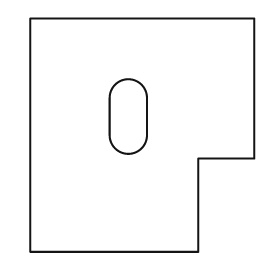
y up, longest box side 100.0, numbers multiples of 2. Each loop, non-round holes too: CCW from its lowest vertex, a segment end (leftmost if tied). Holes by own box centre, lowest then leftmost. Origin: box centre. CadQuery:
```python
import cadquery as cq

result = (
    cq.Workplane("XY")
    .moveTo(-48.0, -50.0)
    .lineTo(24.0, -50.0)
    .lineTo(24.0, -10.0)
    .lineTo(48.0, -10.0)
    .lineTo(48.0, 50.0)
    .lineTo(-48.0, 50.0)
    .close()
    .moveTo(-14.0, 0.0)
    .threePointArc((-6.0, -8.0), (2.0, 0.0))
    .lineTo(2.0, 16.0)
    .threePointArc((-6.0, 24.0), (-14.0, 16.0))
    .close()
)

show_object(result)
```